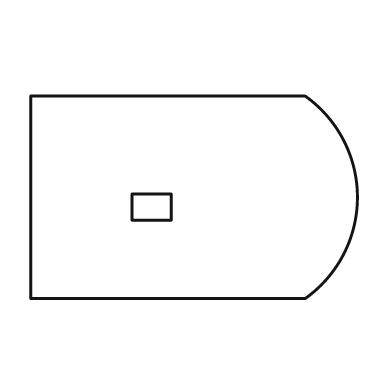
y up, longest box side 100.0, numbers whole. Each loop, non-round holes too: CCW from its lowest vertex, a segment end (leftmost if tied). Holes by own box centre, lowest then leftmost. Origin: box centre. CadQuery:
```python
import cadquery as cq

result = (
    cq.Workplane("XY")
    .moveTo(-50.0, -31.0)
    .lineTo(34.0, -31.0)
    .threePointArc((50.0, 0.0), (34.0, 31.0))
    .lineTo(-50.0, 31.0)
    .close()
    .moveTo(-19.0, -7.0)
    .lineTo(-7.0, -7.0)
    .lineTo(-7.0, 1.0)
    .lineTo(-19.0, 1.0)
    .close()
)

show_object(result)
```